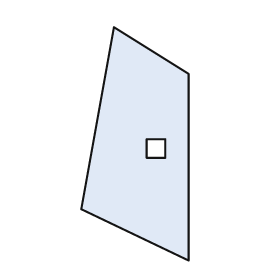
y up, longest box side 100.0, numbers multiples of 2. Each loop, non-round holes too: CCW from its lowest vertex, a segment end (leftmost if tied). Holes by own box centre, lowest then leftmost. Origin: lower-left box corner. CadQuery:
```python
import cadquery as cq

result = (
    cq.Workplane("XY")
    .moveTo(46.0, 0.0)
    .lineTo(46.0, 80.0)
    .lineTo(14.0, 100.0)
    .lineTo(0.0, 22.0)
    .close()
    .moveTo(28.0, 44.0)
    .lineTo(36.0, 44.0)
    .lineTo(36.0, 52.0)
    .lineTo(28.0, 52.0)
    .close()
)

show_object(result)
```